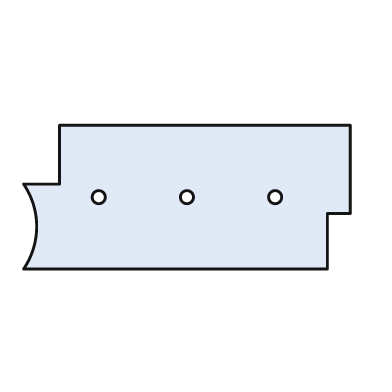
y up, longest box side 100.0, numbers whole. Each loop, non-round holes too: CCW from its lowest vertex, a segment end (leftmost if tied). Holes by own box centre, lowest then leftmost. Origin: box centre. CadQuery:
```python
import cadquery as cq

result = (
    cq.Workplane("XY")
    .moveTo(-50.0, -22.0)
    .lineTo(43.0, -22.0)
    .lineTo(43.0, -5.0)
    .lineTo(50.0, -5.0)
    .lineTo(50.0, 22.0)
    .lineTo(-39.0, 22.0)
    .lineTo(-39.0, 4.0)
    .lineTo(-50.0, 4.0)
    .threePointArc((-46.0, -9.0), (-50.0, -22.0))
    .close()
    .moveTo(-27.0, 0.0)
    .circle(2.0)
    .moveTo(0.0, 0.0)
    .circle(2.0)
    .moveTo(27.0, 0.0)
    .circle(2.0)
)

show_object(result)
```